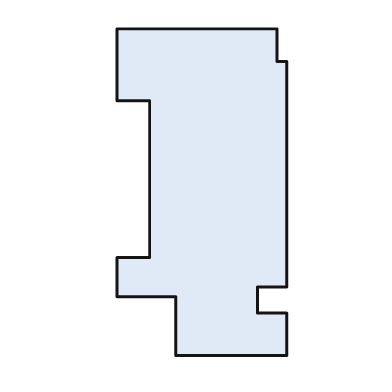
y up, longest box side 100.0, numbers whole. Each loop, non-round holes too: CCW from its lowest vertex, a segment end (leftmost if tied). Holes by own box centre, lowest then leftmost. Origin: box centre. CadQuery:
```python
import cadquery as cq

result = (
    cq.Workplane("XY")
    .moveTo(-8.0, -50.0)
    .lineTo(26.0, -50.0)
    .lineTo(26.0, -37.0)
    .lineTo(17.0, -37.0)
    .lineTo(17.0, -29.0)
    .lineTo(26.0, -29.0)
    .lineTo(26.0, 40.0)
    .lineTo(23.0, 40.0)
    .lineTo(23.0, 50.0)
    .lineTo(-26.0, 50.0)
    .lineTo(-26.0, 28.0)
    .lineTo(-16.0, 28.0)
    .lineTo(-16.0, -20.0)
    .lineTo(-26.0, -20.0)
    .lineTo(-26.0, -32.0)
    .lineTo(-8.0, -32.0)
    .close()
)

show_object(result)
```